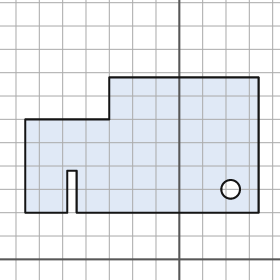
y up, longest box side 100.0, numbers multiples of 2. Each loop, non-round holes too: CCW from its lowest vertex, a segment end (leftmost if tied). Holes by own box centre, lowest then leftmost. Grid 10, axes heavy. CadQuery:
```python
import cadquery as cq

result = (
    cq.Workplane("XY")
    .moveTo(-66.0, 20.0)
    .lineTo(-48.0, 20.0)
    .lineTo(-48.0, 38.0)
    .lineTo(-44.0, 38.0)
    .lineTo(-44.0, 20.0)
    .lineTo(34.0, 20.0)
    .lineTo(34.0, 78.0)
    .lineTo(-30.0, 78.0)
    .lineTo(-30.0, 60.0)
    .lineTo(-66.0, 60.0)
    .close()
    .moveTo(22.0, 30.0)
    .circle(4.0)
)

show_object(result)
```